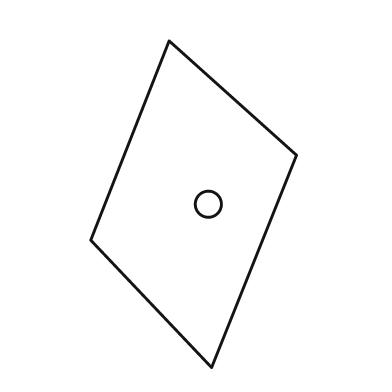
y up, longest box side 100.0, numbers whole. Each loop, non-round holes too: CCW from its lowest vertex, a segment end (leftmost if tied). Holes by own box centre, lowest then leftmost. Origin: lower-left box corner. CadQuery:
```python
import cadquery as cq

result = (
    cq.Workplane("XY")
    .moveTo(37.0, 0.0)
    .lineTo(63.0, 65.0)
    .lineTo(24.0, 100.0)
    .lineTo(0.0, 39.0)
    .close()
    .moveTo(36.0, 50.0)
    .circle(4.0)
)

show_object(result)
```